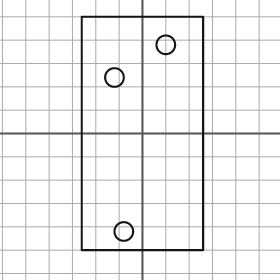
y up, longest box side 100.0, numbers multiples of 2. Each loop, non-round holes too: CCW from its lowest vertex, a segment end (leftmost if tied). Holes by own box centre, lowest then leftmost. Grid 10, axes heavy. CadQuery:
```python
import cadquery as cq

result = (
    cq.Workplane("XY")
    .moveTo(-26.0, -50.0)
    .lineTo(26.0, -50.0)
    .lineTo(26.0, 50.0)
    .lineTo(-26.0, 50.0)
    .close()
    .moveTo(-8.0, -42.0)
    .circle(4.0)
    .moveTo(-12.0, 24.0)
    .circle(4.0)
    .moveTo(10.0, 38.0)
    .circle(4.0)
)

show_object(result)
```